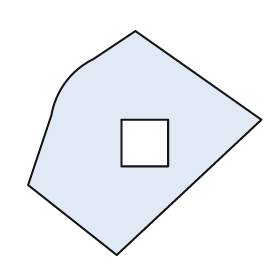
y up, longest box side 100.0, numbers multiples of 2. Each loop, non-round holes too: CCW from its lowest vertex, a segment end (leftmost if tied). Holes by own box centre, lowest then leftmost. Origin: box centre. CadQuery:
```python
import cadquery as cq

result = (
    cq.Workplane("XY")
    .moveTo(-12.0, -48.0)
    .lineTo(50.0, 10.0)
    .lineTo(-4.0, 48.0)
    .lineTo(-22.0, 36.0)
    .threePointArc((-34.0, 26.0), (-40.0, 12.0))
    .lineTo(-50.0, -18.0)
    .close()
    .moveTo(-10.0, -10.0)
    .lineTo(10.0, -10.0)
    .lineTo(10.0, 10.0)
    .lineTo(-10.0, 10.0)
    .close()
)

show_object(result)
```